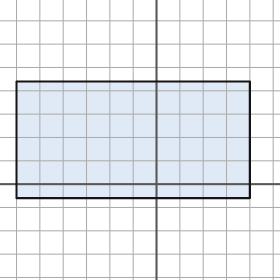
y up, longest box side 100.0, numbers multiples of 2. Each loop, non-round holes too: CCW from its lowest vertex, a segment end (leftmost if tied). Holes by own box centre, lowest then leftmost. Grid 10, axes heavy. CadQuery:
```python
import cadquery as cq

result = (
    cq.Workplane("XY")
    .moveTo(-60.0, -6.0)
    .lineTo(40.0, -6.0)
    .lineTo(40.0, 44.0)
    .lineTo(-60.0, 44.0)
    .close()
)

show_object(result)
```